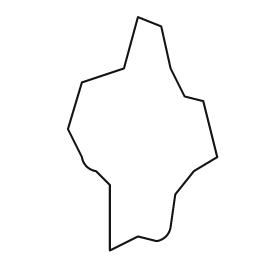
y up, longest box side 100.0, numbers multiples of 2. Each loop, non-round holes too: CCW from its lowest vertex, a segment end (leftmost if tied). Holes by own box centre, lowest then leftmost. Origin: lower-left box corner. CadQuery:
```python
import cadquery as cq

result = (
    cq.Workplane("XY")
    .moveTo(18.0, 0.0)
    .lineTo(30.0, 6.0)
    .lineTo(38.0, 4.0)
    .threePointArc((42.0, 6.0), (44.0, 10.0))
    .lineTo(46.0, 24.0)
    .lineTo(54.0, 34.0)
    .lineTo(64.0, 40.0)
    .lineTo(58.0, 64.0)
    .lineTo(50.0, 66.0)
    .lineTo(44.0, 78.0)
    .lineTo(40.0, 96.0)
    .lineTo(30.0, 100.0)
    .lineTo(24.0, 78.0)
    .lineTo(6.0, 72.0)
    .lineTo(0.0, 52.0)
    .lineTo(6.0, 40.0)
    .threePointArc((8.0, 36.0), (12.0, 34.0))
    .lineTo(18.0, 28.0)
    .close()
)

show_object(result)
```